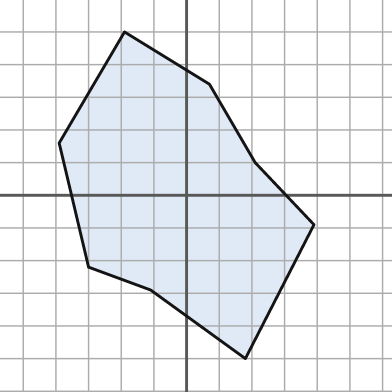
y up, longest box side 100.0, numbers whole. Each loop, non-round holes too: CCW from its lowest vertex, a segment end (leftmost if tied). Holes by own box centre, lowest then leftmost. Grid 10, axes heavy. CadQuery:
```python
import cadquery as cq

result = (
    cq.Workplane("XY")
    .moveTo(18.0, -50.0)
    .lineTo(39.0, -9.0)
    .lineTo(21.0, 10.0)
    .lineTo(7.0, 34.0)
    .lineTo(-19.0, 50.0)
    .lineTo(-39.0, 16.0)
    .lineTo(-30.0, -22.0)
    .lineTo(-11.0, -29.0)
    .close()
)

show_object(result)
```